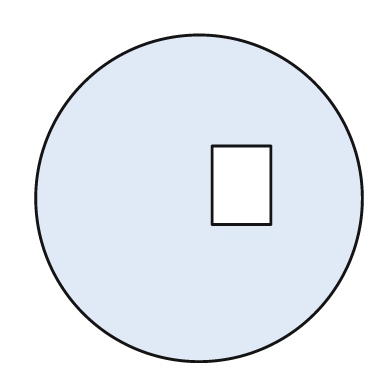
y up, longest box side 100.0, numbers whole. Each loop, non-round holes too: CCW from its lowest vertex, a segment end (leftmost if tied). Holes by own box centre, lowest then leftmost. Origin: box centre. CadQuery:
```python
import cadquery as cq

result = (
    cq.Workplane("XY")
    .moveTo(0.0, 0.0)
    .circle(50.0)
    .moveTo(4.0, -8.0)
    .lineTo(22.0, -8.0)
    .lineTo(22.0, 16.0)
    .lineTo(4.0, 16.0)
    .close()
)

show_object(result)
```